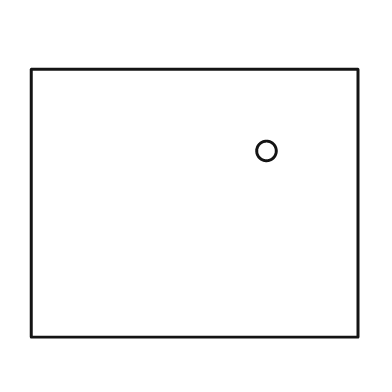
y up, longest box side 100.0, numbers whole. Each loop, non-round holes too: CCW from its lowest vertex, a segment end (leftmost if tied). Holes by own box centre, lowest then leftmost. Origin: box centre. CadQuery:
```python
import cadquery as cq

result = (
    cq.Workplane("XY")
    .moveTo(-50.0, -41.0)
    .lineTo(50.0, -41.0)
    .lineTo(50.0, 41.0)
    .lineTo(-50.0, 41.0)
    .close()
    .moveTo(22.0, 16.0)
    .circle(3.0)
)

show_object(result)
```